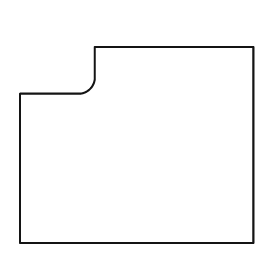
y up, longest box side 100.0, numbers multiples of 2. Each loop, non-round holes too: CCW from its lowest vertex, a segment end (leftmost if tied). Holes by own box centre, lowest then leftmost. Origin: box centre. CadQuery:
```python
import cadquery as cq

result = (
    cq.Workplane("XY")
    .moveTo(-50.0, -42.0)
    .lineTo(50.0, -42.0)
    .lineTo(50.0, 42.0)
    .lineTo(-18.0, 42.0)
    .lineTo(-18.0, 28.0)
    .threePointArc((-20.0, 24.0), (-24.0, 22.0))
    .lineTo(-50.0, 22.0)
    .close()
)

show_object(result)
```